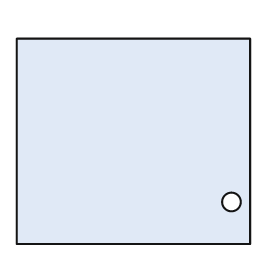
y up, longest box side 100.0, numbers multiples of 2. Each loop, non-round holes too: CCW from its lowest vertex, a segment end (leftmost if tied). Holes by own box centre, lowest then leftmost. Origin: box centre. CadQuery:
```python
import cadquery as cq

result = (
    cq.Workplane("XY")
    .moveTo(-50.0, -44.0)
    .lineTo(50.0, -44.0)
    .lineTo(50.0, 44.0)
    .lineTo(-50.0, 44.0)
    .close()
    .moveTo(42.0, -26.0)
    .circle(4.0)
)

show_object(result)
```